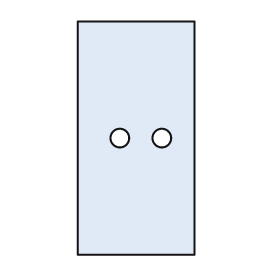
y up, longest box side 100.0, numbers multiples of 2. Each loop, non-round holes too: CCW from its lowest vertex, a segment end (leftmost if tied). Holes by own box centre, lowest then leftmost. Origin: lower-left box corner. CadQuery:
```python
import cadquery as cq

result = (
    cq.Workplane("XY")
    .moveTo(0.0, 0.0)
    .lineTo(50.0, 0.0)
    .lineTo(50.0, 100.0)
    .lineTo(0.0, 100.0)
    .close()
    .moveTo(18.0, 50.0)
    .circle(4.0)
    .moveTo(36.0, 50.0)
    .circle(4.0)
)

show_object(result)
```